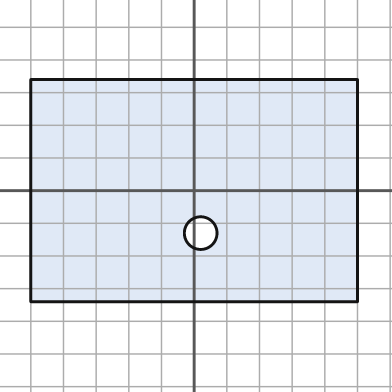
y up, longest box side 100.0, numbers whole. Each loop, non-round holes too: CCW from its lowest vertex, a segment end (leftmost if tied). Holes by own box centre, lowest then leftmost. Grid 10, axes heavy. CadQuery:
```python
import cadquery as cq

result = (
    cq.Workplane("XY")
    .moveTo(-50.0, -34.0)
    .lineTo(50.0, -34.0)
    .lineTo(50.0, 34.0)
    .lineTo(-50.0, 34.0)
    .close()
    .moveTo(2.0, -13.0)
    .circle(5.0)
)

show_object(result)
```